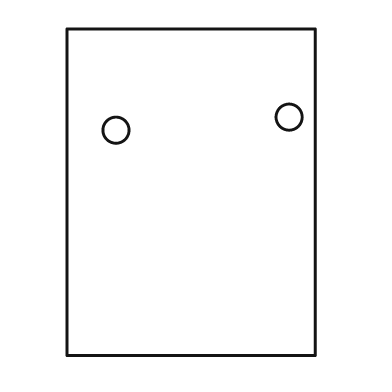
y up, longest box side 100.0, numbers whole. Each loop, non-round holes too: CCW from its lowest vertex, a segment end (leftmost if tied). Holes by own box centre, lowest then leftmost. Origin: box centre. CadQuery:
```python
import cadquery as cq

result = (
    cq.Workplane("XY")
    .moveTo(-38.0, -50.0)
    .lineTo(38.0, -50.0)
    .lineTo(38.0, 50.0)
    .lineTo(-38.0, 50.0)
    .close()
    .moveTo(-23.0, 19.0)
    .circle(4.0)
    .moveTo(30.0, 23.0)
    .circle(4.0)
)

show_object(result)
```